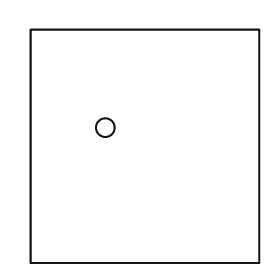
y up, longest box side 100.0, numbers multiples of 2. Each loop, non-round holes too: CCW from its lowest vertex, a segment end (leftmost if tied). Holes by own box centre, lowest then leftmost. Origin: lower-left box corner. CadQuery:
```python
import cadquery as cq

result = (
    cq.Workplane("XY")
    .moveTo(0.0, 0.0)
    .lineTo(98.0, 0.0)
    .lineTo(98.0, 100.0)
    .lineTo(0.0, 100.0)
    .close()
    .moveTo(32.0, 58.0)
    .circle(4.0)
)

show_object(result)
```